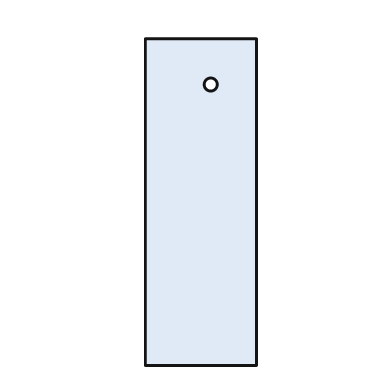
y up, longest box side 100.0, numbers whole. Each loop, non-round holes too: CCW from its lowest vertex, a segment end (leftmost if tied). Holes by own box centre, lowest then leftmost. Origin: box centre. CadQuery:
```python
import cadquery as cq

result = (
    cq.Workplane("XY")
    .moveTo(-17.0, -50.0)
    .lineTo(17.0, -50.0)
    .lineTo(17.0, 50.0)
    .lineTo(-17.0, 50.0)
    .close()
    .moveTo(3.0, 36.0)
    .circle(2.0)
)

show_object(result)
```